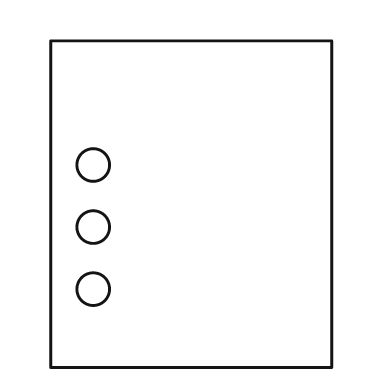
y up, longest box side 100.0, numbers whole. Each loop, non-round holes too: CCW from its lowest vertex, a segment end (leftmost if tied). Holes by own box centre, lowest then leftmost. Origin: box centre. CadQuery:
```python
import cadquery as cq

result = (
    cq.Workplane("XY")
    .moveTo(-43.0, -50.0)
    .lineTo(43.0, -50.0)
    .lineTo(43.0, 50.0)
    .lineTo(-43.0, 50.0)
    .close()
    .moveTo(-30.0, -26.0)
    .circle(5.0)
    .moveTo(-30.0, -7.0)
    .circle(5.0)
    .moveTo(-30.0, 12.0)
    .circle(5.0)
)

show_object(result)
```